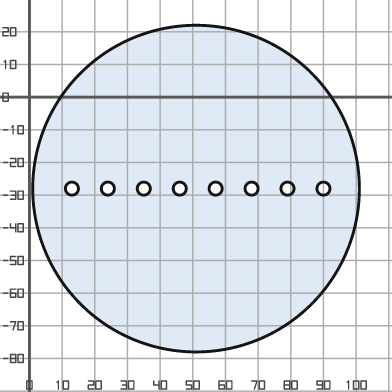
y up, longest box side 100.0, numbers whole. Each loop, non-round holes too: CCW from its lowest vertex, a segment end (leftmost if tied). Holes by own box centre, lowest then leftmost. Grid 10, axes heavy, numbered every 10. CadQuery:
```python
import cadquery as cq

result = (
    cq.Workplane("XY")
    .moveTo(51.0, -28.0)
    .circle(50.0)
    .moveTo(13.0, -28.0)
    .circle(2.0)
    .moveTo(24.0, -28.0)
    .circle(2.0)
    .moveTo(35.0, -28.0)
    .circle(2.0)
    .moveTo(46.0, -28.0)
    .circle(2.0)
    .moveTo(57.0, -28.0)
    .circle(2.0)
    .moveTo(68.0, -28.0)
    .circle(2.0)
    .moveTo(79.0, -28.0)
    .circle(2.0)
    .moveTo(90.0, -28.0)
    .circle(2.0)
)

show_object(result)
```